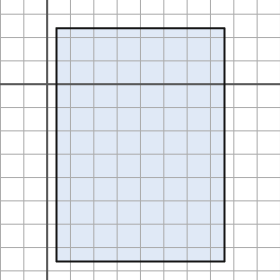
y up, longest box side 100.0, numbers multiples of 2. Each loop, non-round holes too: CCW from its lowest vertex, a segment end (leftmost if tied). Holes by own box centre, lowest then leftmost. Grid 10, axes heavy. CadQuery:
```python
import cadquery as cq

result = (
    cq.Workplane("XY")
    .moveTo(4.0, -76.0)
    .lineTo(76.0, -76.0)
    .lineTo(76.0, 24.0)
    .lineTo(4.0, 24.0)
    .close()
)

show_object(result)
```